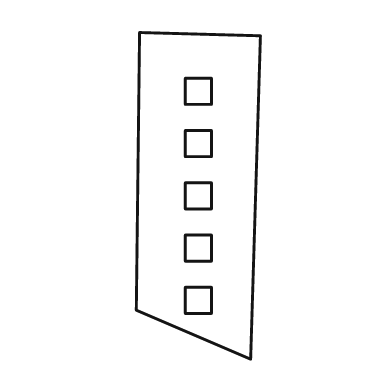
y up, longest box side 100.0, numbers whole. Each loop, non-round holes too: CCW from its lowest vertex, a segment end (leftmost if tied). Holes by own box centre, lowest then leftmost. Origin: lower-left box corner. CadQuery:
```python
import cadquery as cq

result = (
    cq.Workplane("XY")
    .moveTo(35.0, 0.0)
    .lineTo(38.0, 99.0)
    .lineTo(1.0, 100.0)
    .lineTo(0.0, 15.0)
    .close()
    .moveTo(15.0, 14.0)
    .lineTo(23.0, 14.0)
    .lineTo(23.0, 22.0)
    .lineTo(15.0, 22.0)
    .close()
    .moveTo(15.0, 30.0)
    .lineTo(23.0, 30.0)
    .lineTo(23.0, 38.0)
    .lineTo(15.0, 38.0)
    .close()
    .moveTo(15.0, 46.0)
    .lineTo(23.0, 46.0)
    .lineTo(23.0, 54.0)
    .lineTo(15.0, 54.0)
    .close()
    .moveTo(15.0, 62.0)
    .lineTo(23.0, 62.0)
    .lineTo(23.0, 70.0)
    .lineTo(15.0, 70.0)
    .close()
    .moveTo(15.0, 78.0)
    .lineTo(23.0, 78.0)
    .lineTo(23.0, 86.0)
    .lineTo(15.0, 86.0)
    .close()
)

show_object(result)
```